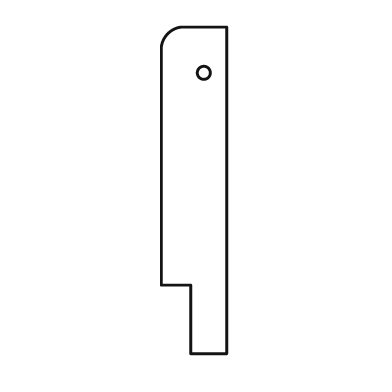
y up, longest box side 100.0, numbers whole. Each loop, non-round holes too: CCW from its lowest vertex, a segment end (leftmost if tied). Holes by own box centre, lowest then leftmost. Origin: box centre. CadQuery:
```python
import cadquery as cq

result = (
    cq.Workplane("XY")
    .moveTo(-1.0, -50.0)
    .lineTo(10.0, -50.0)
    .lineTo(10.0, 50.0)
    .lineTo(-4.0, 50.0)
    .threePointArc((-8.0, 48.0), (-10.0, 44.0))
    .lineTo(-10.0, -29.0)
    .lineTo(-1.0, -29.0)
    .close()
    .moveTo(3.0, 36.0)
    .circle(2.0)
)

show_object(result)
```